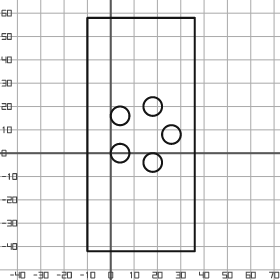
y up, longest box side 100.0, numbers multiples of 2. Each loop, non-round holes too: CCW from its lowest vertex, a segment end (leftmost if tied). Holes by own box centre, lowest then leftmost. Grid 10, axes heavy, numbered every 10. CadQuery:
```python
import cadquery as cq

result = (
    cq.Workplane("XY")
    .moveTo(-10.0, -42.0)
    .lineTo(36.0, -42.0)
    .lineTo(36.0, 58.0)
    .lineTo(-10.0, 58.0)
    .close()
    .moveTo(18.0, -4.0)
    .circle(4.0)
    .moveTo(4.0, 0.0)
    .circle(4.0)
    .moveTo(26.0, 8.0)
    .circle(4.0)
    .moveTo(4.0, 16.0)
    .circle(4.0)
    .moveTo(18.0, 20.0)
    .circle(4.0)
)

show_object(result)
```